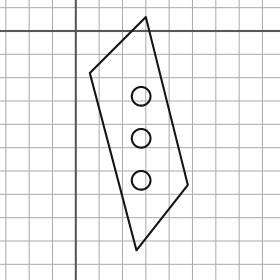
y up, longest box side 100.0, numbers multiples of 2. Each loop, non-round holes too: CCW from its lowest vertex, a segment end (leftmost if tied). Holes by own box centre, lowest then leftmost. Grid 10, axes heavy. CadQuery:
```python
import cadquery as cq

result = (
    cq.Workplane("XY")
    .moveTo(26.0, -94.0)
    .lineTo(48.0, -66.0)
    .lineTo(30.0, 6.0)
    .lineTo(6.0, -18.0)
    .close()
    .moveTo(28.0, -64.0)
    .circle(4.0)
    .moveTo(28.0, -46.0)
    .circle(4.0)
    .moveTo(28.0, -28.0)
    .circle(4.0)
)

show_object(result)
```